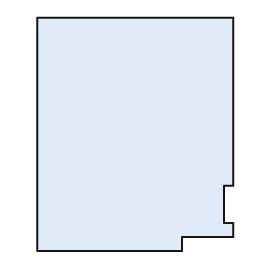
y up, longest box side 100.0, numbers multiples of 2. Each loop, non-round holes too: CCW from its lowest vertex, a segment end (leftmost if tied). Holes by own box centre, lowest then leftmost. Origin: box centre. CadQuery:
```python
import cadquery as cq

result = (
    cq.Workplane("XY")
    .moveTo(-42.0, -50.0)
    .lineTo(20.0, -50.0)
    .lineTo(20.0, -44.0)
    .lineTo(42.0, -44.0)
    .lineTo(42.0, -38.0)
    .lineTo(38.0, -38.0)
    .lineTo(38.0, -22.0)
    .lineTo(42.0, -22.0)
    .lineTo(42.0, 50.0)
    .lineTo(-42.0, 50.0)
    .close()
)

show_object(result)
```